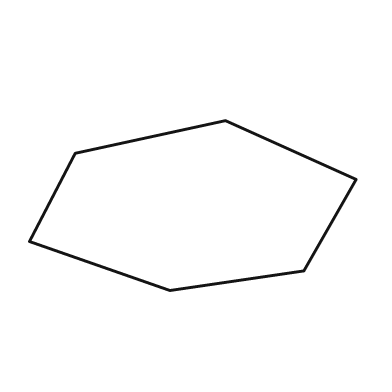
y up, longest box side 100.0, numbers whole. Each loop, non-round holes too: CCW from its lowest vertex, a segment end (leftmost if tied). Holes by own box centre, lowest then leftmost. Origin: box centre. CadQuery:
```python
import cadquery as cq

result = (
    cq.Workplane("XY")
    .moveTo(-7.0, -26.0)
    .lineTo(34.0, -20.0)
    .lineTo(50.0, 8.0)
    .lineTo(10.0, 26.0)
    .lineTo(-36.0, 16.0)
    .lineTo(-50.0, -11.0)
    .close()
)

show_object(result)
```